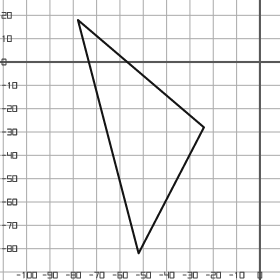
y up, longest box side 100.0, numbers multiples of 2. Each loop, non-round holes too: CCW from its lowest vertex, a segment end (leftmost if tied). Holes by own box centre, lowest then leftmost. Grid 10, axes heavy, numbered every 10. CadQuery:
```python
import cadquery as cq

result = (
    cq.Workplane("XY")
    .moveTo(-52.0, -82.0)
    .lineTo(-24.0, -28.0)
    .lineTo(-78.0, 18.0)
    .close()
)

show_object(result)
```